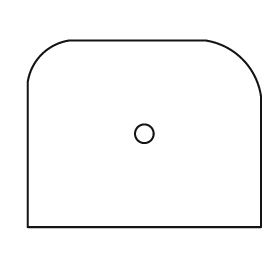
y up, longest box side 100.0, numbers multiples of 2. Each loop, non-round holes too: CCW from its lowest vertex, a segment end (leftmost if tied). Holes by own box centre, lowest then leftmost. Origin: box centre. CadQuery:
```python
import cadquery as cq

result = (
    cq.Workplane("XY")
    .moveTo(-50.0, -40.0)
    .lineTo(50.0, -40.0)
    .lineTo(50.0, 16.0)
    .threePointArc((42.0, 32.0), (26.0, 40.0))
    .lineTo(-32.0, 40.0)
    .threePointArc((-44.0, 34.0), (-50.0, 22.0))
    .close()
    .moveTo(0.0, 0.0)
    .circle(4.0)
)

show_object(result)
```